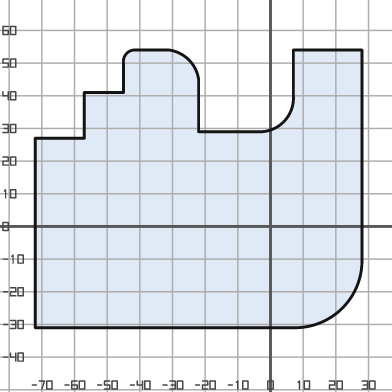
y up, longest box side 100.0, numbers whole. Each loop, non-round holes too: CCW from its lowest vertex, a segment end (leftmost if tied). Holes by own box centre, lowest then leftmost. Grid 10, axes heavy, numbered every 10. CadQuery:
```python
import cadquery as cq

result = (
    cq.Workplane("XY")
    .moveTo(-72.0, -31.0)
    .lineTo(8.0, -31.0)
    .threePointArc((22.0, -25.0), (28.0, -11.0))
    .lineTo(28.0, 54.0)
    .lineTo(7.0, 54.0)
    .lineTo(7.0, 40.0)
    .threePointArc((4.0, 32.0), (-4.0, 29.0))
    .lineTo(-22.0, 29.0)
    .lineTo(-22.0, 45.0)
    .threePointArc((-25.0, 51.0), (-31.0, 54.0))
    .lineTo(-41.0, 54.0)
    .threePointArc((-44.0, 53.0), (-45.0, 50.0))
    .lineTo(-45.0, 41.0)
    .lineTo(-57.0, 41.0)
    .lineTo(-57.0, 27.0)
    .lineTo(-72.0, 27.0)
    .close()
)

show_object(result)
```